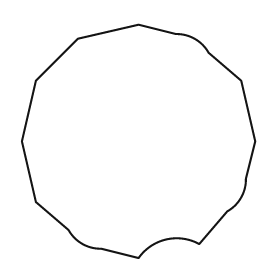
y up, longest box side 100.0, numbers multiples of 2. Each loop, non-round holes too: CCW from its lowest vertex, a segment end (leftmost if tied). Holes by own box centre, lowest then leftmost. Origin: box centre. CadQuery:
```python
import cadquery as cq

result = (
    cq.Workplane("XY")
    .moveTo(0.0, -50.0)
    .threePointArc((12.0, -42.0), (26.0, -44.0))
    .lineTo(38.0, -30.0)
    .threePointArc((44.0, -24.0), (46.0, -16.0))
    .lineTo(50.0, 0.0)
    .lineTo(44.0, 26.0)
    .lineTo(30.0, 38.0)
    .threePointArc((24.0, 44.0), (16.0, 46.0))
    .lineTo(0.0, 50.0)
    .lineTo(-26.0, 44.0)
    .lineTo(-44.0, 26.0)
    .lineTo(-50.0, 0.0)
    .lineTo(-44.0, -26.0)
    .lineTo(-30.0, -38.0)
    .threePointArc((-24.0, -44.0), (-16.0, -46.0))
    .close()
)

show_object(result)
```